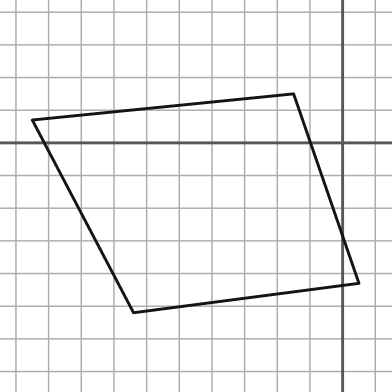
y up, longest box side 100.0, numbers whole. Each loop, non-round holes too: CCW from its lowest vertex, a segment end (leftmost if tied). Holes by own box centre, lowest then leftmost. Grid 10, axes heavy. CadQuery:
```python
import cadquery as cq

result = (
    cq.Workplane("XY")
    .moveTo(-64.0, -52.0)
    .lineTo(5.0, -43.0)
    .lineTo(-15.0, 15.0)
    .lineTo(-95.0, 7.0)
    .close()
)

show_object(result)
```